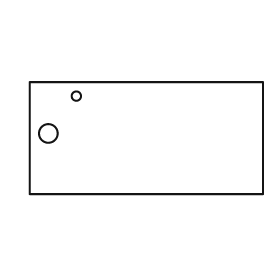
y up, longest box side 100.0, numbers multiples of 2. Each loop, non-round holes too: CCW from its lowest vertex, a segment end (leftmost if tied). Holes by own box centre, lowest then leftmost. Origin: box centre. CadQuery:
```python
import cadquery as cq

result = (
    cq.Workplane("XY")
    .moveTo(-50.0, -24.0)
    .lineTo(50.0, -24.0)
    .lineTo(50.0, 24.0)
    .lineTo(-50.0, 24.0)
    .close()
    .moveTo(-42.0, 2.0)
    .circle(4.0)
    .moveTo(-30.0, 18.0)
    .circle(2.0)
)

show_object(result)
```